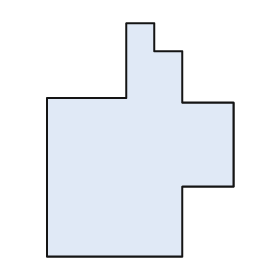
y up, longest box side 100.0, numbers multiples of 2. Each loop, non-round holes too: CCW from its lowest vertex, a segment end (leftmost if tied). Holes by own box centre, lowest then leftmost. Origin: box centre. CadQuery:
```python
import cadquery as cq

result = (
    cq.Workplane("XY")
    .moveTo(-40.0, -50.0)
    .lineTo(18.0, -50.0)
    .lineTo(18.0, -20.0)
    .lineTo(40.0, -20.0)
    .lineTo(40.0, 16.0)
    .lineTo(18.0, 16.0)
    .lineTo(18.0, 38.0)
    .lineTo(6.0, 38.0)
    .lineTo(6.0, 50.0)
    .lineTo(-6.0, 50.0)
    .lineTo(-6.0, 18.0)
    .lineTo(-40.0, 18.0)
    .close()
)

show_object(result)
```